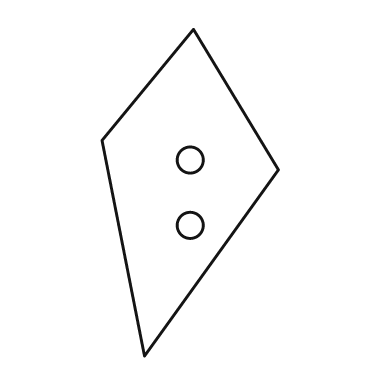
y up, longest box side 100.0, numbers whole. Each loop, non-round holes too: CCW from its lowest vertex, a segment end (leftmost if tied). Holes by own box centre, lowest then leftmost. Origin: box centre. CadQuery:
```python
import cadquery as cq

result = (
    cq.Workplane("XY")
    .moveTo(-14.0, -50.0)
    .lineTo(27.0, 7.0)
    .lineTo(1.0, 50.0)
    .lineTo(-27.0, 16.0)
    .close()
    .moveTo(0.0, -10.0)
    .circle(4.0)
    .moveTo(0.0, 10.0)
    .circle(4.0)
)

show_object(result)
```